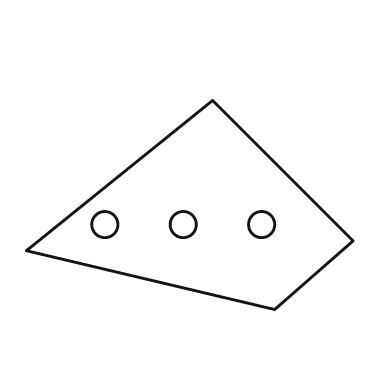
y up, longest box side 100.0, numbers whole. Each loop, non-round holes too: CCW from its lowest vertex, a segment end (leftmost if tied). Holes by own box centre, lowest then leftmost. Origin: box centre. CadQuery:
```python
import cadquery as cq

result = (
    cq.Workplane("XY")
    .moveTo(26.0, -32.0)
    .lineTo(50.0, -11.0)
    .lineTo(7.0, 32.0)
    .lineTo(-50.0, -14.0)
    .close()
    .moveTo(-26.0, -6.0)
    .circle(4.0)
    .moveTo(-2.0, -6.0)
    .circle(4.0)
    .moveTo(22.0, -6.0)
    .circle(4.0)
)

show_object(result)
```